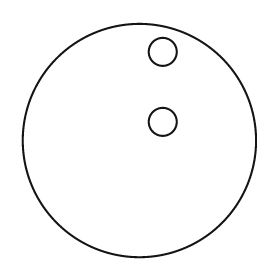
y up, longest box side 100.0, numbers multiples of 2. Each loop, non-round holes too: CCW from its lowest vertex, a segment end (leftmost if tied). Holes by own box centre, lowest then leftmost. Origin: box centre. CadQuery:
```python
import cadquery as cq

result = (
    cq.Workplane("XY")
    .moveTo(0.0, 0.0)
    .circle(50.0)
    .moveTo(10.0, 8.0)
    .circle(6.0)
    .moveTo(10.0, 38.0)
    .circle(6.0)
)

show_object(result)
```